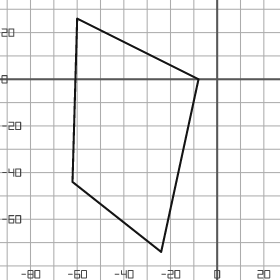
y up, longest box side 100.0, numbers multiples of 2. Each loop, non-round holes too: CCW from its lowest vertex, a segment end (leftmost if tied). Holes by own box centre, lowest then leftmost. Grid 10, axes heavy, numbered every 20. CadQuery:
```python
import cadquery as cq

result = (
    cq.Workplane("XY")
    .moveTo(-24.0, -74.0)
    .lineTo(-8.0, 0.0)
    .lineTo(-60.0, 26.0)
    .lineTo(-62.0, -44.0)
    .close()
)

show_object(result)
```